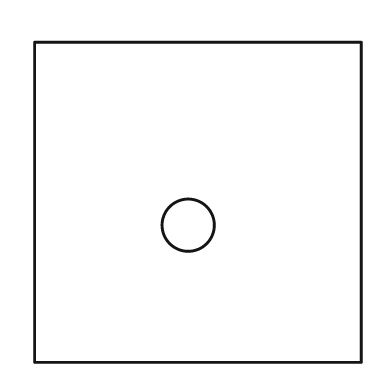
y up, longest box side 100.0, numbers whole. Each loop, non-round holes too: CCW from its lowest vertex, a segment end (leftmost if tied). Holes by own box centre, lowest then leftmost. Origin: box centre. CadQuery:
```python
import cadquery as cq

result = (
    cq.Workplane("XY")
    .moveTo(-50.0, -49.0)
    .lineTo(50.0, -49.0)
    .lineTo(50.0, 49.0)
    .lineTo(-50.0, 49.0)
    .close()
    .moveTo(-3.0, -7.0)
    .circle(8.0)
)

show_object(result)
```